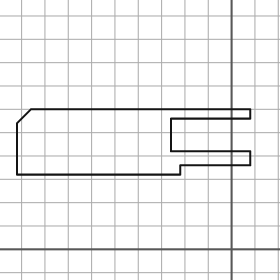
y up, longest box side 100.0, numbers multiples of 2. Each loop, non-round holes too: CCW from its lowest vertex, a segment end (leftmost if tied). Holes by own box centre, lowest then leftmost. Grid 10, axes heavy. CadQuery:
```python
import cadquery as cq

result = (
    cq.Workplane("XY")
    .moveTo(-92.0, 32.0)
    .lineTo(-22.0, 32.0)
    .lineTo(-22.0, 36.0)
    .lineTo(8.0, 36.0)
    .lineTo(8.0, 42.0)
    .lineTo(-26.0, 42.0)
    .lineTo(-26.0, 56.0)
    .lineTo(8.0, 56.0)
    .lineTo(8.0, 60.0)
    .lineTo(-86.0, 60.0)
    .lineTo(-92.0, 54.0)
    .close()
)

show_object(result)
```